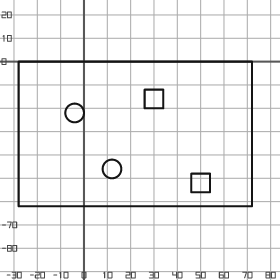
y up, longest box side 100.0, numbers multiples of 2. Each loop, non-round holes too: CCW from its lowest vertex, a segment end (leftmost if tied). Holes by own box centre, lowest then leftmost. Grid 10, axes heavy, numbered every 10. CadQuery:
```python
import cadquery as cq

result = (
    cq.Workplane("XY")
    .moveTo(-28.0, -62.0)
    .lineTo(72.0, -62.0)
    .lineTo(72.0, 0.0)
    .lineTo(-28.0, 0.0)
    .close()
    .moveTo(46.0, -56.0)
    .lineTo(54.0, -56.0)
    .lineTo(54.0, -48.0)
    .lineTo(46.0, -48.0)
    .close()
    .moveTo(12.0, -46.0)
    .circle(4.0)
    .moveTo(-4.0, -22.0)
    .circle(4.0)
    .moveTo(26.0, -20.0)
    .lineTo(34.0, -20.0)
    .lineTo(34.0, -12.0)
    .lineTo(26.0, -12.0)
    .close()
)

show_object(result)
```